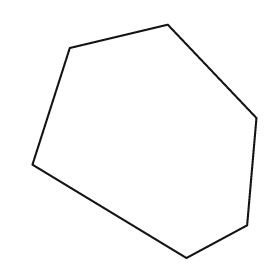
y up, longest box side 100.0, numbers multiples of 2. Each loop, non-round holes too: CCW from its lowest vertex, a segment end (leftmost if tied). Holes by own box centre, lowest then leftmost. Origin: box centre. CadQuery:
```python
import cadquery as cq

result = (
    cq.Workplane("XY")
    .moveTo(18.0, -50.0)
    .lineTo(44.0, -36.0)
    .lineTo(48.0, 10.0)
    .lineTo(10.0, 50.0)
    .lineTo(-32.0, 40.0)
    .lineTo(-48.0, -10.0)
    .close()
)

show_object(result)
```